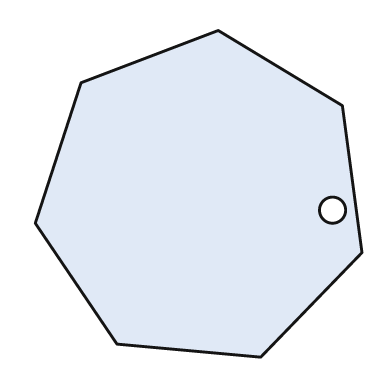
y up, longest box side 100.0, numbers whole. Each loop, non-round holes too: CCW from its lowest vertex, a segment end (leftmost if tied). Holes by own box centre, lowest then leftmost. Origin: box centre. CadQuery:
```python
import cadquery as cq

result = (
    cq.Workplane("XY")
    .moveTo(19.0, -50.0)
    .lineTo(50.0, -18.0)
    .lineTo(44.0, 27.0)
    .lineTo(6.0, 50.0)
    .lineTo(-36.0, 34.0)
    .lineTo(-50.0, -9.0)
    .lineTo(-25.0, -46.0)
    .close()
    .moveTo(41.0, -5.0)
    .circle(4.0)
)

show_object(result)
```